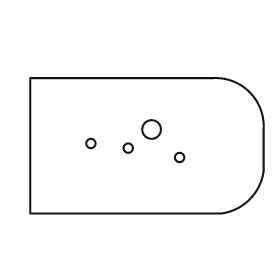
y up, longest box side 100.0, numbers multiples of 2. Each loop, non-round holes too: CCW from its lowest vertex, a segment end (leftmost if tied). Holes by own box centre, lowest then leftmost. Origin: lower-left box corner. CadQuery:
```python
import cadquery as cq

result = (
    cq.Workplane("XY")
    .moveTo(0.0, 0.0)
    .lineTo(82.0, 0.0)
    .threePointArc((94.0, 6.0), (100.0, 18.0))
    .lineTo(100.0, 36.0)
    .threePointArc((94.0, 52.0), (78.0, 58.0))
    .lineTo(0.0, 58.0)
    .close()
    .moveTo(64.0, 24.0)
    .circle(2.0)
    .moveTo(42.0, 28.0)
    .circle(2.0)
    .moveTo(26.0, 30.0)
    .circle(2.0)
    .moveTo(52.0, 36.0)
    .circle(4.0)
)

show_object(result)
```